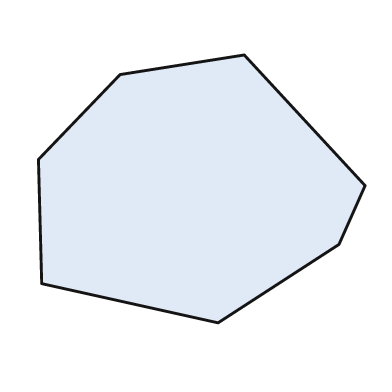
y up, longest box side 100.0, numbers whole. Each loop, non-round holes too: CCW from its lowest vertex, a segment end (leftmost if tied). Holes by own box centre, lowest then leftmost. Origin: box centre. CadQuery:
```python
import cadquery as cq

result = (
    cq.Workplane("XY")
    .moveTo(5.0, -41.0)
    .lineTo(42.0, -17.0)
    .lineTo(50.0, 1.0)
    .lineTo(13.0, 41.0)
    .lineTo(-25.0, 35.0)
    .lineTo(-50.0, 9.0)
    .lineTo(-49.0, -29.0)
    .close()
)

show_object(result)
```